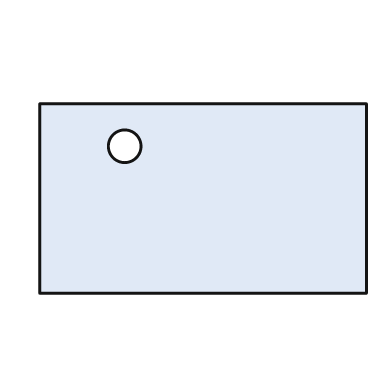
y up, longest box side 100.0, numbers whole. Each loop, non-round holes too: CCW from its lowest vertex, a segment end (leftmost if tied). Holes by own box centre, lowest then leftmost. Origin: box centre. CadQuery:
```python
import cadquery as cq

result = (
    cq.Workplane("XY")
    .moveTo(-50.0, -29.0)
    .lineTo(50.0, -29.0)
    .lineTo(50.0, 29.0)
    .lineTo(-50.0, 29.0)
    .close()
    .moveTo(-24.0, 16.0)
    .circle(5.0)
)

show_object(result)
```